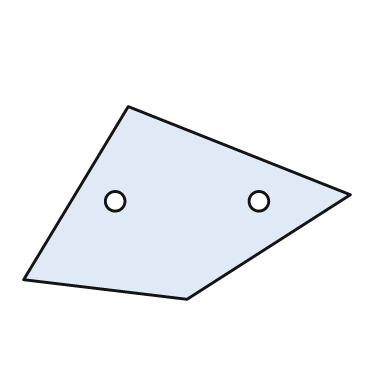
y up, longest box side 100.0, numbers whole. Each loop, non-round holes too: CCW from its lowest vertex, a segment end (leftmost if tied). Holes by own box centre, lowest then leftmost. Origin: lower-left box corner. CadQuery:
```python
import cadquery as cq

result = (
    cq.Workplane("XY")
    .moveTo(50.0, 0.0)
    .lineTo(100.0, 32.0)
    .lineTo(32.0, 59.0)
    .lineTo(0.0, 6.0)
    .close()
    .moveTo(28.0, 30.0)
    .circle(3.0)
    .moveTo(72.0, 30.0)
    .circle(3.0)
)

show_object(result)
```